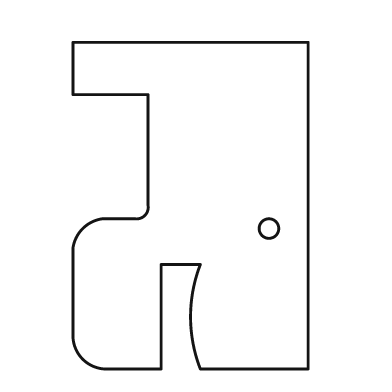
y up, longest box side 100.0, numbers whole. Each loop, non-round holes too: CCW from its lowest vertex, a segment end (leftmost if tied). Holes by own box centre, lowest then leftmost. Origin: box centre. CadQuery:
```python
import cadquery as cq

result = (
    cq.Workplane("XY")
    .moveTo(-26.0, -50.0)
    .lineTo(-9.0, -50.0)
    .lineTo(-9.0, -18.0)
    .lineTo(3.0, -18.0)
    .threePointArc((0.0, -34.0), (3.0, -50.0))
    .lineTo(36.0, -50.0)
    .lineTo(36.0, 50.0)
    .lineTo(-36.0, 50.0)
    .lineTo(-36.0, 34.0)
    .lineTo(-13.0, 34.0)
    .lineTo(-13.0, 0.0)
    .threePointArc((-14.0, -3.0), (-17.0, -4.0))
    .lineTo(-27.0, -4.0)
    .threePointArc((-33.0, -7.0), (-36.0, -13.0))
    .lineTo(-36.0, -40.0)
    .threePointArc((-33.0, -47.0), (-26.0, -50.0))
    .close()
    .moveTo(24.0, -7.0)
    .circle(3.0)
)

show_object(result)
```